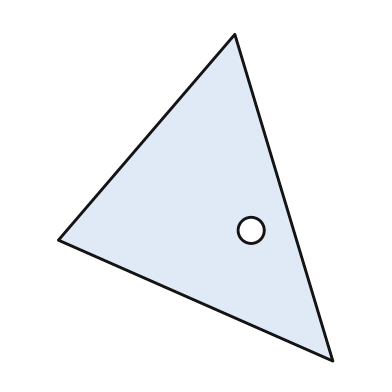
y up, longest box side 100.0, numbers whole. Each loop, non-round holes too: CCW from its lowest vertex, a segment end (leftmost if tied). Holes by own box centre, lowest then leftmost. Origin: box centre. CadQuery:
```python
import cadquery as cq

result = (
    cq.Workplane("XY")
    .moveTo(42.0, -50.0)
    .lineTo(12.0, 50.0)
    .lineTo(-42.0, -13.0)
    .close()
    .moveTo(17.0, -10.0)
    .circle(4.0)
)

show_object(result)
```